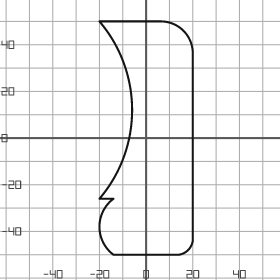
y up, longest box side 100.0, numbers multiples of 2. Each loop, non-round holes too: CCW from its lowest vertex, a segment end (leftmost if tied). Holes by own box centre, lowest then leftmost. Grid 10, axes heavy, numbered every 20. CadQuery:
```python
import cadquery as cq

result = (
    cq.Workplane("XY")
    .moveTo(-14.0, -50.0)
    .lineTo(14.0, -50.0)
    .threePointArc((18.0, -48.0), (20.0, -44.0))
    .lineTo(20.0, 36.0)
    .threePointArc((16.0, 46.0), (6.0, 50.0))
    .lineTo(-20.0, 50.0)
    .threePointArc((-6.0, 12.0), (-20.0, -26.0))
    .lineTo(-14.0, -26.0)
    .threePointArc((-20.0, -38.0), (-14.0, -50.0))
    .close()
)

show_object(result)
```